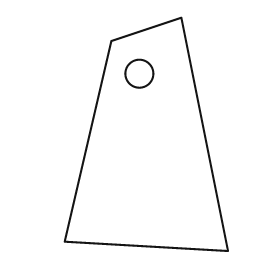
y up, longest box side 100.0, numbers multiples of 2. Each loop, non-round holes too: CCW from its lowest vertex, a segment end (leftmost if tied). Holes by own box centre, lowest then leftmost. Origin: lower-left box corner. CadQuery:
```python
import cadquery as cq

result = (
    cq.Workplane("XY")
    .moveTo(70.0, 0.0)
    .lineTo(50.0, 100.0)
    .lineTo(20.0, 90.0)
    .lineTo(0.0, 4.0)
    .close()
    .moveTo(32.0, 76.0)
    .circle(6.0)
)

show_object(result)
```